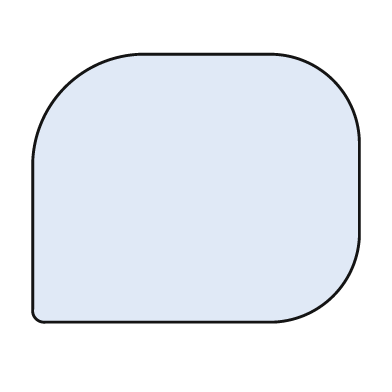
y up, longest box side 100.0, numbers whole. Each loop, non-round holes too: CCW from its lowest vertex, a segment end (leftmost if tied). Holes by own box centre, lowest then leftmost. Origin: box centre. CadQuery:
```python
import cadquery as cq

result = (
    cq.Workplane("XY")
    .moveTo(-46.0, -41.0)
    .lineTo(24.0, -41.0)
    .threePointArc((42.0, -33.0), (50.0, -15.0))
    .lineTo(50.0, 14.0)
    .threePointArc((42.0, 33.0), (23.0, 41.0))
    .lineTo(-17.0, 41.0)
    .threePointArc((-40.0, 31.0), (-50.0, 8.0))
    .lineTo(-50.0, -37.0)
    .threePointArc((-49.0, -40.0), (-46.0, -41.0))
    .close()
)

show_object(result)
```